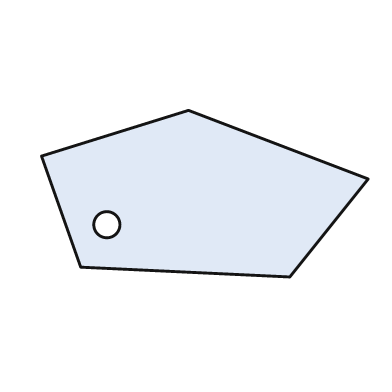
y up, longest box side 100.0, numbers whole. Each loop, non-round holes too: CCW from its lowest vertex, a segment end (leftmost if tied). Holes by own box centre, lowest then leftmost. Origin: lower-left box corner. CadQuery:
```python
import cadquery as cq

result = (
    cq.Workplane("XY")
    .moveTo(76.0, 0.0)
    .lineTo(100.0, 30.0)
    .lineTo(45.0, 51.0)
    .lineTo(0.0, 37.0)
    .lineTo(12.0, 3.0)
    .close()
    .moveTo(20.0, 16.0)
    .circle(4.0)
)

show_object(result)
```